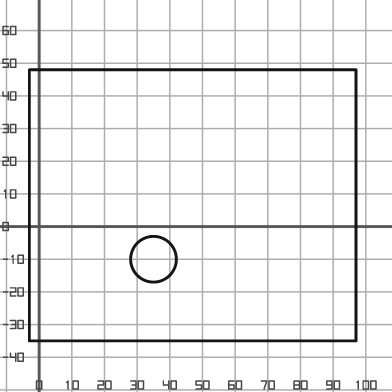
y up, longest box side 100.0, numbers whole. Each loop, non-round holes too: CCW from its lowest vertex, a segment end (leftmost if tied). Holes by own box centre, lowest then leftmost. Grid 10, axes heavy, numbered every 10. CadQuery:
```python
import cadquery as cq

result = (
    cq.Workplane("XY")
    .moveTo(-3.0, -35.0)
    .lineTo(97.0, -35.0)
    .lineTo(97.0, 48.0)
    .lineTo(-3.0, 48.0)
    .close()
    .moveTo(35.0, -10.0)
    .circle(7.0)
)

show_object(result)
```